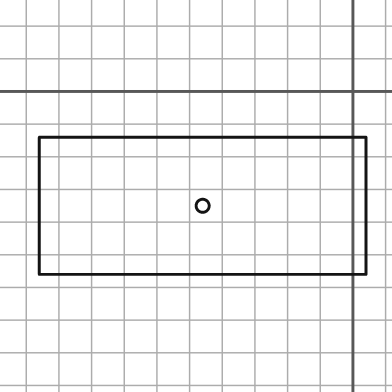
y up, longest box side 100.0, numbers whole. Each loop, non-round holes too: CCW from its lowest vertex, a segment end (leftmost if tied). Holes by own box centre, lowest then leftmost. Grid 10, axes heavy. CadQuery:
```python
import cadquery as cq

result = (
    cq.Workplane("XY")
    .moveTo(-96.0, -56.0)
    .lineTo(4.0, -56.0)
    .lineTo(4.0, -14.0)
    .lineTo(-96.0, -14.0)
    .close()
    .moveTo(-46.0, -35.0)
    .circle(2.0)
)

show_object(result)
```